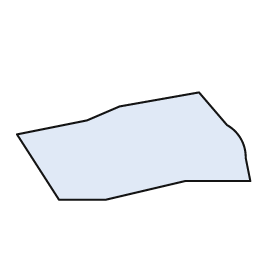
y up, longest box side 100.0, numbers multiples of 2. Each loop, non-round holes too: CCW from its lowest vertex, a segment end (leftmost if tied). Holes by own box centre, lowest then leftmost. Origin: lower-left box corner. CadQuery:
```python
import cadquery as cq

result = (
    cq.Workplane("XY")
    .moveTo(18.0, 0.0)
    .lineTo(38.0, 0.0)
    .lineTo(72.0, 8.0)
    .lineTo(100.0, 8.0)
    .lineTo(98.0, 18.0)
    .threePointArc((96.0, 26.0), (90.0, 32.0))
    .lineTo(78.0, 46.0)
    .lineTo(44.0, 40.0)
    .lineTo(30.0, 34.0)
    .lineTo(0.0, 28.0)
    .close()
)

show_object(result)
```